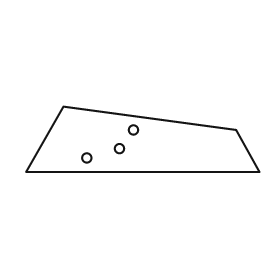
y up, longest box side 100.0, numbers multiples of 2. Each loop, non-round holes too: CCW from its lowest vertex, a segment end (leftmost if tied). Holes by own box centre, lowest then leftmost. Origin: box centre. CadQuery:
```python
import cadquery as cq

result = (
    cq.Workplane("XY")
    .moveTo(-50.0, -14.0)
    .lineTo(50.0, -14.0)
    .lineTo(40.0, 4.0)
    .lineTo(-34.0, 14.0)
    .close()
    .moveTo(-24.0, -8.0)
    .circle(2.0)
    .moveTo(-10.0, -4.0)
    .circle(2.0)
    .moveTo(-4.0, 4.0)
    .circle(2.0)
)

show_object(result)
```